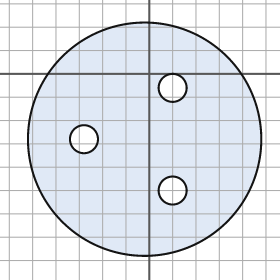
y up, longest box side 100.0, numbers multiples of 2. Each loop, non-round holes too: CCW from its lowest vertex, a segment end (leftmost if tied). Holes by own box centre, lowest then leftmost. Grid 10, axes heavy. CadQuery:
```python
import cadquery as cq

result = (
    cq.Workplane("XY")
    .moveTo(-2.0, -28.0)
    .circle(50.0)
    .moveTo(10.0, -50.0)
    .circle(6.0)
    .moveTo(-28.0, -28.0)
    .circle(6.0)
    .moveTo(10.0, -6.0)
    .circle(6.0)
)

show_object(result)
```